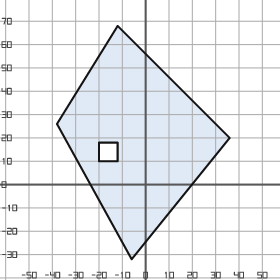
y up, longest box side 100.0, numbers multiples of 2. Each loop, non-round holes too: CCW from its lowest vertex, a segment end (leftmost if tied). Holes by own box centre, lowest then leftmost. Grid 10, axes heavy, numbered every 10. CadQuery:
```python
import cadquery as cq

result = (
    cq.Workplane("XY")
    .moveTo(-6.0, -32.0)
    .lineTo(36.0, 20.0)
    .lineTo(-12.0, 68.0)
    .lineTo(-38.0, 26.0)
    .close()
    .moveTo(-20.0, 10.0)
    .lineTo(-12.0, 10.0)
    .lineTo(-12.0, 18.0)
    .lineTo(-20.0, 18.0)
    .close()
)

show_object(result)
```